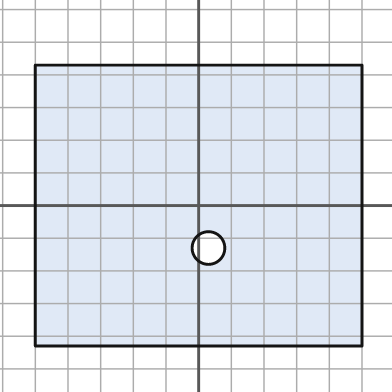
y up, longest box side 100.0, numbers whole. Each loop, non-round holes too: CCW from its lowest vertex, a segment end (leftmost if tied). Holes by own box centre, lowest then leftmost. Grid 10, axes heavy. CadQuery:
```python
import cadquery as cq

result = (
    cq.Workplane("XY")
    .moveTo(-50.0, -43.0)
    .lineTo(50.0, -43.0)
    .lineTo(50.0, 43.0)
    .lineTo(-50.0, 43.0)
    .close()
    .moveTo(3.0, -13.0)
    .circle(5.0)
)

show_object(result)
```